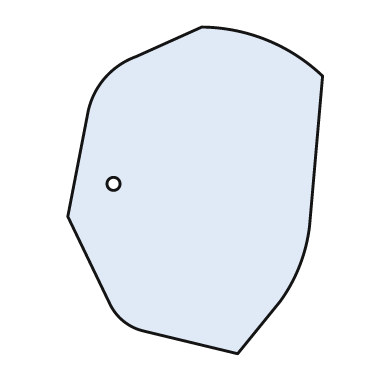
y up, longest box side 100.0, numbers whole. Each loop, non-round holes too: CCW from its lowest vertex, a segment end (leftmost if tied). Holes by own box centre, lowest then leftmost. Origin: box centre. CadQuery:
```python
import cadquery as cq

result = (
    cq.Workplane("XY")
    .moveTo(13.0, -50.0)
    .lineTo(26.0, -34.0)
    .threePointArc((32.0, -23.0), (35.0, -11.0))
    .lineTo(39.0, 35.0)
    .threePointArc((22.0, 46.0), (2.0, 50.0))
    .lineTo(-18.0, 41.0)
    .threePointArc((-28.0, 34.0), (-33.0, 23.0))
    .lineTo(-39.0, -8.0)
    .lineTo(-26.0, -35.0)
    .threePointArc((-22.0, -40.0), (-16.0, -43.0))
    .close()
    .moveTo(-25.0, 2.0)
    .circle(2.0)
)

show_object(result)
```